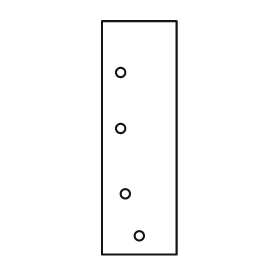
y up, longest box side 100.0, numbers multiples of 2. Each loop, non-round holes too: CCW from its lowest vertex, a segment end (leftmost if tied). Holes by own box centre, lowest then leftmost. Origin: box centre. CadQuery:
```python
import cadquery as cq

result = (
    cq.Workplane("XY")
    .moveTo(-16.0, -50.0)
    .lineTo(16.0, -50.0)
    .lineTo(16.0, 50.0)
    .lineTo(-16.0, 50.0)
    .close()
    .moveTo(0.0, -42.0)
    .circle(2.0)
    .moveTo(-6.0, -24.0)
    .circle(2.0)
    .moveTo(-8.0, 4.0)
    .circle(2.0)
    .moveTo(-8.0, 28.0)
    .circle(2.0)
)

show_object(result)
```